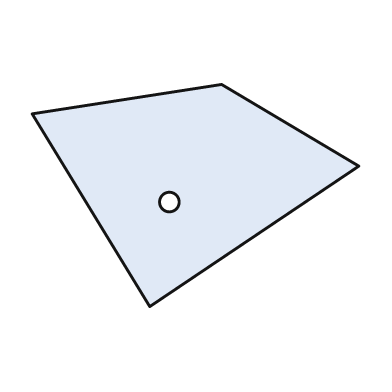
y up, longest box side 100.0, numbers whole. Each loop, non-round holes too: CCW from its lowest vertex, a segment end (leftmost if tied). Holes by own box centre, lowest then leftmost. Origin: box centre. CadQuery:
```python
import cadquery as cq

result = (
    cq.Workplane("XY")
    .moveTo(-14.0, -34.0)
    .lineTo(50.0, 9.0)
    .lineTo(8.0, 34.0)
    .lineTo(-50.0, 25.0)
    .close()
    .moveTo(-8.0, -2.0)
    .circle(3.0)
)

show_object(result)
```